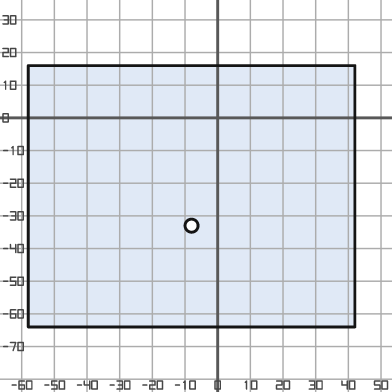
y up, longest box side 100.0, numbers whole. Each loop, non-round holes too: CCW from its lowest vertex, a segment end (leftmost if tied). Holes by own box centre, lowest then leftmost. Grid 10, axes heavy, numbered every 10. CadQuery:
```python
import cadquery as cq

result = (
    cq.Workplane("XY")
    .moveTo(-58.0, -64.0)
    .lineTo(42.0, -64.0)
    .lineTo(42.0, 16.0)
    .lineTo(-58.0, 16.0)
    .close()
    .moveTo(-8.0, -33.0)
    .circle(2.0)
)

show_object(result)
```